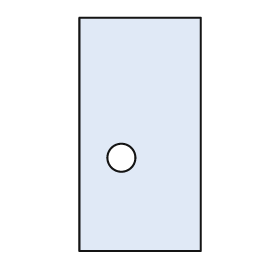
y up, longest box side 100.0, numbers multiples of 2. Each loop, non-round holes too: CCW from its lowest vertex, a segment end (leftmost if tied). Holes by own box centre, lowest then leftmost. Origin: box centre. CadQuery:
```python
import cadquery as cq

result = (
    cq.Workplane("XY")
    .moveTo(-26.0, -50.0)
    .lineTo(26.0, -50.0)
    .lineTo(26.0, 50.0)
    .lineTo(-26.0, 50.0)
    .close()
    .moveTo(-8.0, -10.0)
    .circle(6.0)
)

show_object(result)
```